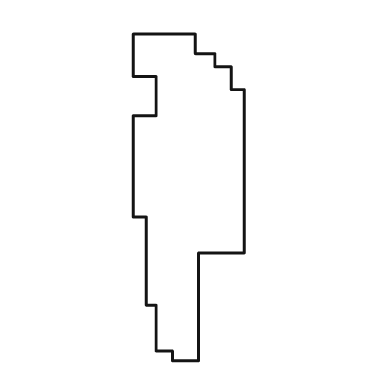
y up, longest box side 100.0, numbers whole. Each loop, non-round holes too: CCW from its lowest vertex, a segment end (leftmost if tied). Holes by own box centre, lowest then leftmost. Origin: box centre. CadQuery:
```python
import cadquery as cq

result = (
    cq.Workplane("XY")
    .moveTo(-5.0, -50.0)
    .lineTo(3.0, -50.0)
    .lineTo(3.0, -17.0)
    .lineTo(17.0, -17.0)
    .lineTo(17.0, 33.0)
    .lineTo(13.0, 33.0)
    .lineTo(13.0, 40.0)
    .lineTo(8.0, 40.0)
    .lineTo(8.0, 44.0)
    .lineTo(2.0, 44.0)
    .lineTo(2.0, 50.0)
    .lineTo(-17.0, 50.0)
    .lineTo(-17.0, 37.0)
    .lineTo(-10.0, 37.0)
    .lineTo(-10.0, 25.0)
    .lineTo(-17.0, 25.0)
    .lineTo(-17.0, -6.0)
    .lineTo(-13.0, -6.0)
    .lineTo(-13.0, -33.0)
    .lineTo(-10.0, -33.0)
    .lineTo(-10.0, -47.0)
    .lineTo(-5.0, -47.0)
    .close()
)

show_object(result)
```